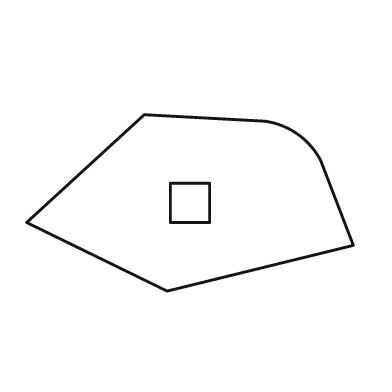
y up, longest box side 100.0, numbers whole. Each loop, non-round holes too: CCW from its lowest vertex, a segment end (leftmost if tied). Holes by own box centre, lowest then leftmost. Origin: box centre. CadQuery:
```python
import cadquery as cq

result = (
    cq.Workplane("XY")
    .moveTo(-7.0, -27.0)
    .lineTo(50.0, -13.0)
    .lineTo(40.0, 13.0)
    .threePointArc((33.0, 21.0), (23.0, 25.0))
    .lineTo(-14.0, 27.0)
    .lineTo(-50.0, -6.0)
    .close()
    .moveTo(-6.0, -6.0)
    .lineTo(6.0, -6.0)
    .lineTo(6.0, 6.0)
    .lineTo(-6.0, 6.0)
    .close()
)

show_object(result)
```